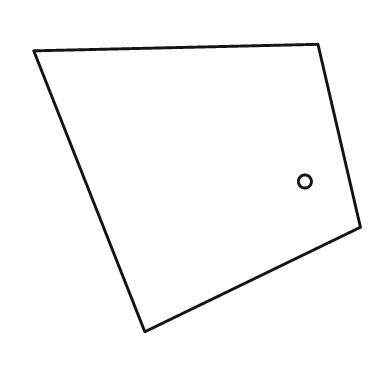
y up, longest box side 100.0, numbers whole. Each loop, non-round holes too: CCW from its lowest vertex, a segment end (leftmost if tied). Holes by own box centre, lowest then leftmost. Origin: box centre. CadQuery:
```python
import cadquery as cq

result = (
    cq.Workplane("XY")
    .moveTo(-16.0, -44.0)
    .lineTo(50.0, -12.0)
    .lineTo(37.0, 44.0)
    .lineTo(-50.0, 42.0)
    .close()
    .moveTo(33.0, 2.0)
    .circle(2.0)
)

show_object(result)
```